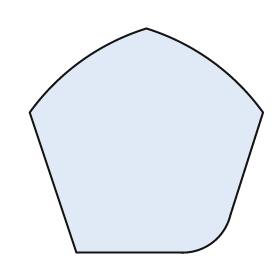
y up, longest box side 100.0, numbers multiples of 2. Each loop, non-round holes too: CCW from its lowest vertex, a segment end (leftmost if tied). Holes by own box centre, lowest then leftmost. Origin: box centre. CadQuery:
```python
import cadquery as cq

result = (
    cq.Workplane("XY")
    .moveTo(-30.0, -48.0)
    .lineTo(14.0, -48.0)
    .threePointArc((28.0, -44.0), (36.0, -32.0))
    .lineTo(50.0, 12.0)
    .threePointArc((28.0, 34.0), (0.0, 48.0))
    .threePointArc((-28.0, 34.0), (-50.0, 12.0))
    .close()
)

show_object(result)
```